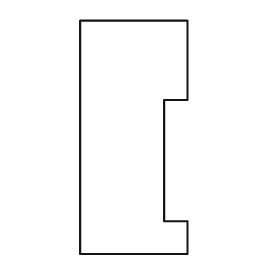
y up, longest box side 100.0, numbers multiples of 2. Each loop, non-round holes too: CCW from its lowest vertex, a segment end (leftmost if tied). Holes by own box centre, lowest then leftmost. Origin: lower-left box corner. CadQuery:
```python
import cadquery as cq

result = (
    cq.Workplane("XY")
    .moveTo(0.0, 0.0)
    .lineTo(46.0, 0.0)
    .lineTo(46.0, 14.0)
    .lineTo(36.0, 14.0)
    .lineTo(36.0, 66.0)
    .lineTo(46.0, 66.0)
    .lineTo(46.0, 100.0)
    .lineTo(0.0, 100.0)
    .close()
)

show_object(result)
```